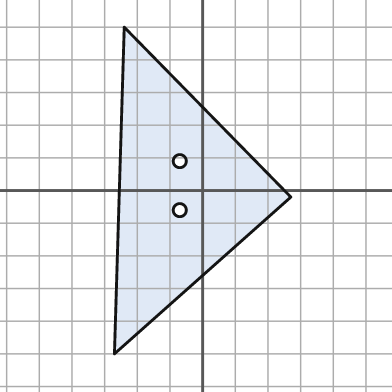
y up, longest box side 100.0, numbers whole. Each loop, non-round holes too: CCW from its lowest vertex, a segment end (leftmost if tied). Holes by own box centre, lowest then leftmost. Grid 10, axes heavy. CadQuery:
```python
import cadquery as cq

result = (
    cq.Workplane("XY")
    .moveTo(-27.0, -50.0)
    .lineTo(27.0, -2.0)
    .lineTo(-24.0, 50.0)
    .close()
    .moveTo(-7.0, -6.0)
    .circle(2.0)
    .moveTo(-7.0, 9.0)
    .circle(2.0)
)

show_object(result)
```